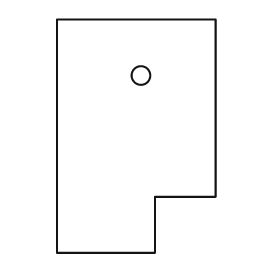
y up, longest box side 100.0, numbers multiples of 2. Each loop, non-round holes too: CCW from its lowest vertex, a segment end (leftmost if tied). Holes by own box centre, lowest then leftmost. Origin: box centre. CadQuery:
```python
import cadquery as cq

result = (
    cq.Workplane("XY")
    .moveTo(-34.0, -50.0)
    .lineTo(8.0, -50.0)
    .lineTo(8.0, -26.0)
    .lineTo(34.0, -26.0)
    .lineTo(34.0, 50.0)
    .lineTo(-34.0, 50.0)
    .close()
    .moveTo(2.0, 26.0)
    .circle(4.0)
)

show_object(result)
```